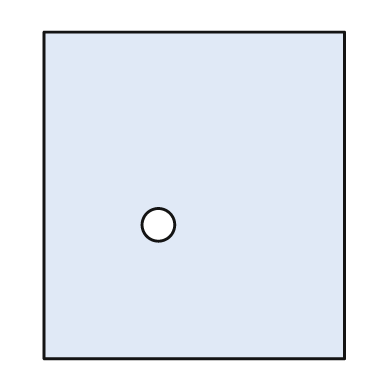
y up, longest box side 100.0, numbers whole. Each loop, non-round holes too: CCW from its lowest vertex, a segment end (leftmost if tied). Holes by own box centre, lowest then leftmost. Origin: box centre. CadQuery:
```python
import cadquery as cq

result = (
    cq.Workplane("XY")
    .moveTo(-46.0, -50.0)
    .lineTo(46.0, -50.0)
    .lineTo(46.0, 50.0)
    .lineTo(-46.0, 50.0)
    .close()
    .moveTo(-11.0, -9.0)
    .circle(5.0)
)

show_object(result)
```